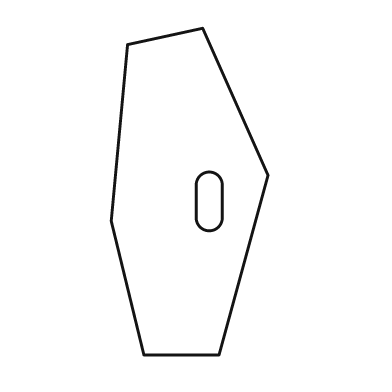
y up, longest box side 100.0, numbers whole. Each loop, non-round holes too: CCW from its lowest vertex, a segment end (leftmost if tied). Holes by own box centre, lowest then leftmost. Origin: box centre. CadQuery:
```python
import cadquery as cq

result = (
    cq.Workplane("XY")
    .moveTo(-14.0, -50.0)
    .lineTo(9.0, -50.0)
    .lineTo(24.0, 5.0)
    .lineTo(4.0, 50.0)
    .lineTo(-19.0, 45.0)
    .lineTo(-24.0, -9.0)
    .close()
    .moveTo(2.0, -8.0)
    .threePointArc((6.0, -12.0), (10.0, -8.0))
    .lineTo(10.0, 2.0)
    .threePointArc((6.0, 6.0), (2.0, 2.0))
    .close()
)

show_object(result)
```